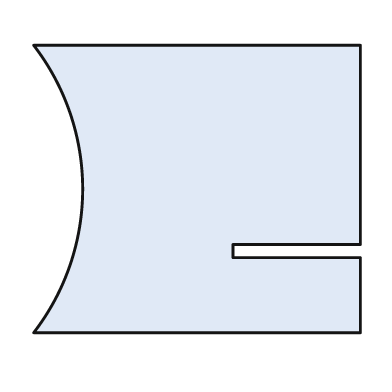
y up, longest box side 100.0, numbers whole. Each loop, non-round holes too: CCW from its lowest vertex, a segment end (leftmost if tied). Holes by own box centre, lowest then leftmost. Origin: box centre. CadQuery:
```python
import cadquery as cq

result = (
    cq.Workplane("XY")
    .moveTo(-50.0, -44.0)
    .lineTo(50.0, -44.0)
    .lineTo(50.0, -21.0)
    .lineTo(11.0, -21.0)
    .lineTo(11.0, -17.0)
    .lineTo(50.0, -17.0)
    .lineTo(50.0, 44.0)
    .lineTo(-50.0, 44.0)
    .threePointArc((-35.0, 0.0), (-50.0, -44.0))
    .close()
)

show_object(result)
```